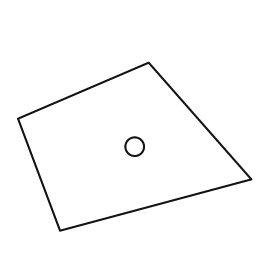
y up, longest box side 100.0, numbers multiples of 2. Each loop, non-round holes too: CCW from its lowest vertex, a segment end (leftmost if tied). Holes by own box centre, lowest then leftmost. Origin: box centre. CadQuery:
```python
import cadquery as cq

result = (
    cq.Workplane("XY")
    .moveTo(-32.0, -36.0)
    .lineTo(50.0, -14.0)
    .lineTo(6.0, 36.0)
    .lineTo(-50.0, 12.0)
    .close()
    .moveTo(0.0, 0.0)
    .circle(4.0)
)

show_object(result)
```